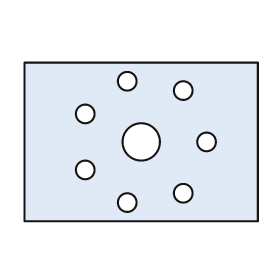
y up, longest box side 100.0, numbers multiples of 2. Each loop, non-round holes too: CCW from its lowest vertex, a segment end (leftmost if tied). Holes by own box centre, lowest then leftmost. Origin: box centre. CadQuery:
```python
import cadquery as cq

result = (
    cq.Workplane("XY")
    .moveTo(-50.0, -34.0)
    .lineTo(50.0, -34.0)
    .lineTo(50.0, 34.0)
    .lineTo(-50.0, 34.0)
    .close()
    .moveTo(-6.0, -26.0)
    .circle(4.0)
    .moveTo(18.0, -22.0)
    .circle(4.0)
    .moveTo(-24.0, -12.0)
    .circle(4.0)
    .moveTo(0.0, 0.0)
    .circle(8.0)
    .moveTo(28.0, 0.0)
    .circle(4.0)
    .moveTo(-24.0, 12.0)
    .circle(4.0)
    .moveTo(18.0, 22.0)
    .circle(4.0)
    .moveTo(-6.0, 26.0)
    .circle(4.0)
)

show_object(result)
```